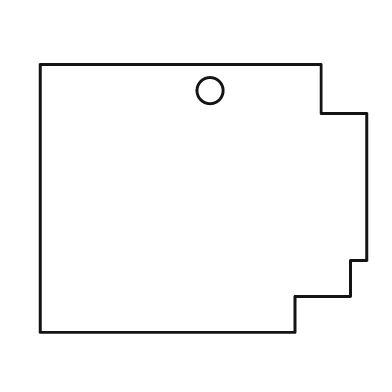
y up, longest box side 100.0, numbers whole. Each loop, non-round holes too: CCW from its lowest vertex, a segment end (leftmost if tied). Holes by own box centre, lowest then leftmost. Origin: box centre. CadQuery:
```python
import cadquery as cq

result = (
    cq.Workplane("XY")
    .moveTo(-50.0, -41.0)
    .lineTo(28.0, -41.0)
    .lineTo(28.0, -30.0)
    .lineTo(45.0, -30.0)
    .lineTo(45.0, -19.0)
    .lineTo(50.0, -19.0)
    .lineTo(50.0, 26.0)
    .lineTo(36.0, 26.0)
    .lineTo(36.0, 41.0)
    .lineTo(-50.0, 41.0)
    .close()
    .moveTo(2.0, 33.0)
    .circle(4.0)
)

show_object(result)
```